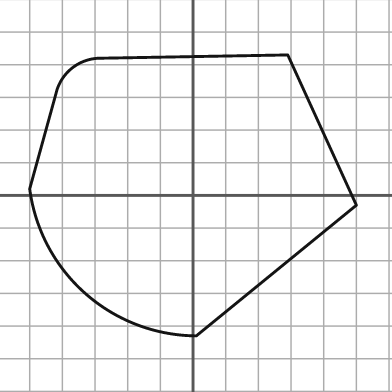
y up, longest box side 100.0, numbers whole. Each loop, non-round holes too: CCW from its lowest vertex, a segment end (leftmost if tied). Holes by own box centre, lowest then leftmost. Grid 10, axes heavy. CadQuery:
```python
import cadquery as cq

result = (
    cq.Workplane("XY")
    .moveTo(1.0, -43.0)
    .lineTo(50.0, -3.0)
    .lineTo(29.0, 43.0)
    .lineTo(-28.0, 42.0)
    .threePointArc((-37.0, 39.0), (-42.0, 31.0))
    .lineTo(-50.0, 2.0)
    .threePointArc((-33.0, -30.0), (1.0, -43.0))
    .close()
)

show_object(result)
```